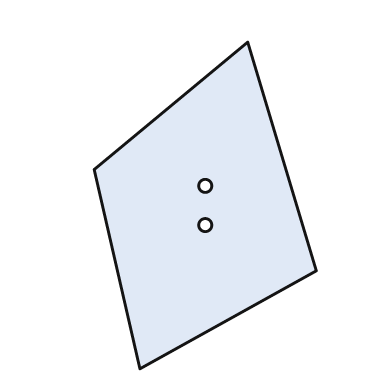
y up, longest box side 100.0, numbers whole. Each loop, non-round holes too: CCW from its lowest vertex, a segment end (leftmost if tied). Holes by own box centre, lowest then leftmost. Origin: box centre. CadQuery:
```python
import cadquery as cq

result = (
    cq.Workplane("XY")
    .moveTo(-20.0, -50.0)
    .lineTo(34.0, -20.0)
    .lineTo(13.0, 50.0)
    .lineTo(-34.0, 11.0)
    .close()
    .moveTo(0.0, -6.0)
    .circle(2.0)
    .moveTo(0.0, 6.0)
    .circle(2.0)
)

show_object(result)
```